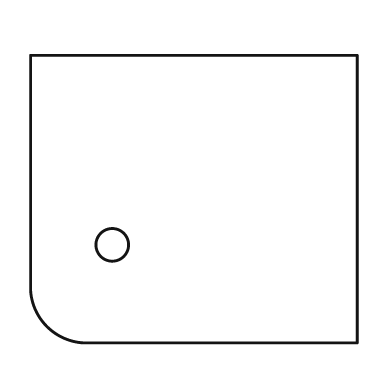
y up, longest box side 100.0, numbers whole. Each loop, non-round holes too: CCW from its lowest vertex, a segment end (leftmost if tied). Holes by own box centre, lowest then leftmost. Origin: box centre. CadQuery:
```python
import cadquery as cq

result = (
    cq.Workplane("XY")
    .moveTo(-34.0, -44.0)
    .lineTo(50.0, -44.0)
    .lineTo(50.0, 44.0)
    .lineTo(-50.0, 44.0)
    .lineTo(-50.0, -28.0)
    .threePointArc((-45.0, -39.0), (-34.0, -44.0))
    .close()
    .moveTo(-25.0, -14.0)
    .circle(5.0)
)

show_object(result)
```